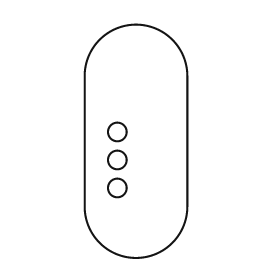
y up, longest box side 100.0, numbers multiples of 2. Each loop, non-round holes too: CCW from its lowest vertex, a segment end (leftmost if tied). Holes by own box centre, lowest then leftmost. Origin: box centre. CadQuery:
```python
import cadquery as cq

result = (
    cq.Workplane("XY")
    .moveTo(-22.0, -28.0)
    .threePointArc((0.0, -50.0), (22.0, -28.0))
    .lineTo(22.0, 28.0)
    .threePointArc((0.0, 50.0), (-22.0, 28.0))
    .close()
    .moveTo(-8.0, -20.0)
    .circle(4.0)
    .moveTo(-8.0, -8.0)
    .circle(4.0)
    .moveTo(-8.0, 4.0)
    .circle(4.0)
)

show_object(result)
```